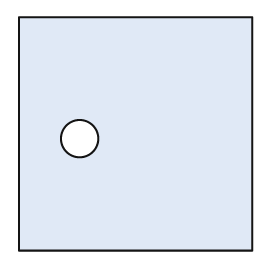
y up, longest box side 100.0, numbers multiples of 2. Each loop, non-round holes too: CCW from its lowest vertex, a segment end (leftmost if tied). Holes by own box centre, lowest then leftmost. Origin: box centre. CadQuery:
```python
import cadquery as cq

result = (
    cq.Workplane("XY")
    .moveTo(-50.0, -50.0)
    .lineTo(50.0, -50.0)
    .lineTo(50.0, 50.0)
    .lineTo(-50.0, 50.0)
    .close()
    .moveTo(-24.0, -2.0)
    .circle(8.0)
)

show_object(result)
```